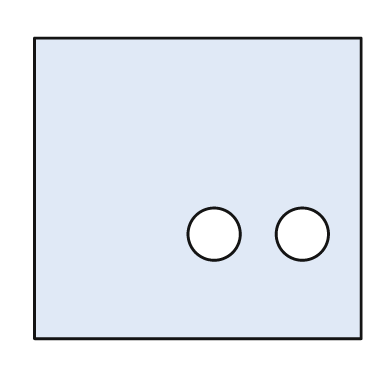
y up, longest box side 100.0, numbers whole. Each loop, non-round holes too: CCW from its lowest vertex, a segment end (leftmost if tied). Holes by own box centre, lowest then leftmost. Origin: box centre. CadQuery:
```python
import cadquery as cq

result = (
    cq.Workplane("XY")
    .moveTo(-50.0, -46.0)
    .lineTo(50.0, -46.0)
    .lineTo(50.0, 46.0)
    .lineTo(-50.0, 46.0)
    .close()
    .moveTo(5.0, -14.0)
    .circle(8.0)
    .moveTo(32.0, -14.0)
    .circle(8.0)
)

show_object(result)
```